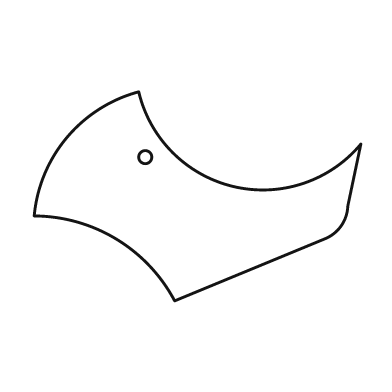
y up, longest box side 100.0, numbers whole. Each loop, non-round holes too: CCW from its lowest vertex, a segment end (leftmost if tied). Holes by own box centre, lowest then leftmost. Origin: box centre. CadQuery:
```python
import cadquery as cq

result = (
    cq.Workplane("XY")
    .moveTo(-7.0, -32.0)
    .lineTo(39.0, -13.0)
    .threePointArc((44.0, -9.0), (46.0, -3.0))
    .lineTo(50.0, 16.0)
    .threePointArc((11.0, 3.0), (-18.0, 32.0))
    .threePointArc((-40.0, 18.0), (-50.0, -6.0))
    .threePointArc((-25.0, -13.0), (-7.0, -32.0))
    .close()
    .moveTo(-16.0, 12.0)
    .circle(2.0)
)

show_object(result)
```